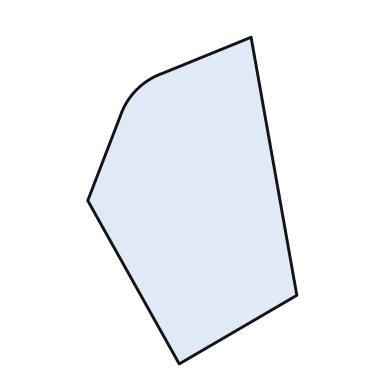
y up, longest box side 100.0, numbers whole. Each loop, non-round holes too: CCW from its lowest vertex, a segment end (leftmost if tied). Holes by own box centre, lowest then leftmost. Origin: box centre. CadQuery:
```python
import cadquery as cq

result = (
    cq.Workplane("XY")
    .moveTo(-4.0, -50.0)
    .lineTo(32.0, -29.0)
    .lineTo(18.0, 50.0)
    .lineTo(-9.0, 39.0)
    .threePointArc((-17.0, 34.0), (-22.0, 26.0))
    .lineTo(-32.0, 0.0)
    .close()
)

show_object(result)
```